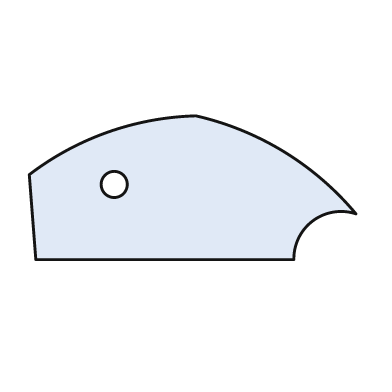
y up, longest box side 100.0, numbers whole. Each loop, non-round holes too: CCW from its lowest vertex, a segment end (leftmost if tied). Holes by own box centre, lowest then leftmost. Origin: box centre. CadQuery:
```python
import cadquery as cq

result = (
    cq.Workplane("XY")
    .moveTo(-48.0, -22.0)
    .lineTo(31.0, -22.0)
    .threePointArc((37.0, -10.0), (50.0, -8.0))
    .threePointArc((28.0, 11.0), (1.0, 22.0))
    .threePointArc((-26.0, 17.0), (-50.0, 4.0))
    .close()
    .moveTo(-24.0, 1.0)
    .circle(4.0)
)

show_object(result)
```